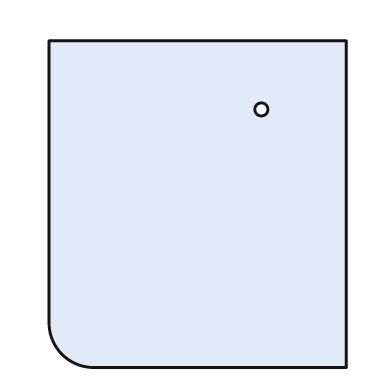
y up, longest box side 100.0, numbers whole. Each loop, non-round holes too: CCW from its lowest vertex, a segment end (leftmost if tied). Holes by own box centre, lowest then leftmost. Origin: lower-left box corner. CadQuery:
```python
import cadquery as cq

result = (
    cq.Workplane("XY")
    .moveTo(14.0, 0.0)
    .lineTo(91.0, 0.0)
    .lineTo(91.0, 100.0)
    .lineTo(0.0, 100.0)
    .lineTo(0.0, 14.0)
    .threePointArc((4.0, 4.0), (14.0, 0.0))
    .close()
    .moveTo(65.0, 79.0)
    .circle(2.0)
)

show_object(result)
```